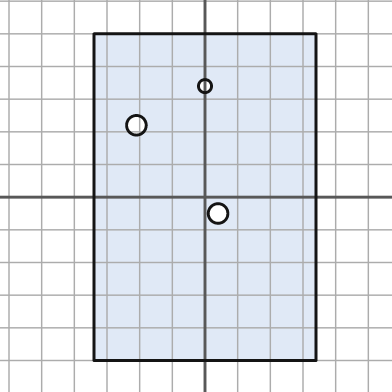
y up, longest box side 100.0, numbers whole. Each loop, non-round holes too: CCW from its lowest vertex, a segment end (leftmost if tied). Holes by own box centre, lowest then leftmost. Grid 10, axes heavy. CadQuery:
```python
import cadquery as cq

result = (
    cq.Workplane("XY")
    .moveTo(-34.0, -50.0)
    .lineTo(34.0, -50.0)
    .lineTo(34.0, 50.0)
    .lineTo(-34.0, 50.0)
    .close()
    .moveTo(4.0, -5.0)
    .circle(3.0)
    .moveTo(-21.0, 22.0)
    .circle(3.0)
    .moveTo(0.0, 34.0)
    .circle(2.0)
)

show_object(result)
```